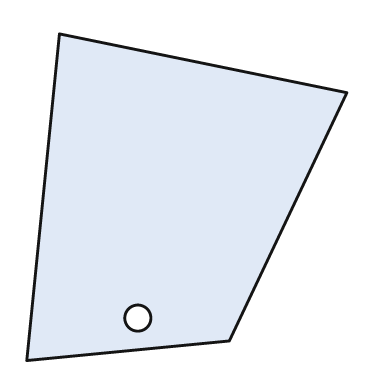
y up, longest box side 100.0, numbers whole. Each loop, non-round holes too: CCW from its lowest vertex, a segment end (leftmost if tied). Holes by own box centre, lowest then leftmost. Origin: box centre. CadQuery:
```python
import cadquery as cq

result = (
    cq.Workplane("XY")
    .moveTo(-49.0, -50.0)
    .lineTo(13.0, -44.0)
    .lineTo(49.0, 32.0)
    .lineTo(-39.0, 50.0)
    .close()
    .moveTo(-15.0, -37.0)
    .circle(4.0)
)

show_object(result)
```